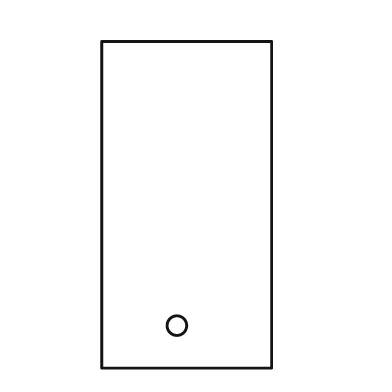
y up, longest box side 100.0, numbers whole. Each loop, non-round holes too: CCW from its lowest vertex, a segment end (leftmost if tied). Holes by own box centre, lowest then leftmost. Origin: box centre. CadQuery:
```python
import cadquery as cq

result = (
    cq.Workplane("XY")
    .moveTo(-26.0, -50.0)
    .lineTo(26.0, -50.0)
    .lineTo(26.0, 50.0)
    .lineTo(-26.0, 50.0)
    .close()
    .moveTo(-3.0, -37.0)
    .circle(3.0)
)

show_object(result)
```